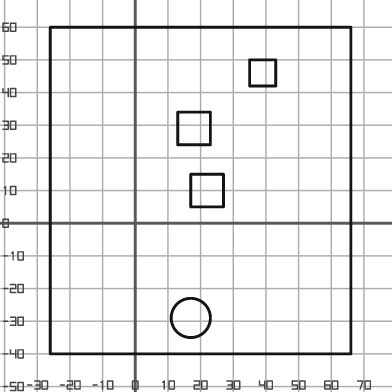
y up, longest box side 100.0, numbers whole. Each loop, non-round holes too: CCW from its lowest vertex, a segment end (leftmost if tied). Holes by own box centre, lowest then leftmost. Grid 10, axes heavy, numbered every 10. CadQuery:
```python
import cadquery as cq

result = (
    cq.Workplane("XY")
    .moveTo(-26.0, -40.0)
    .lineTo(66.0, -40.0)
    .lineTo(66.0, 60.0)
    .lineTo(-26.0, 60.0)
    .close()
    .moveTo(17.0, -29.0)
    .circle(6.0)
    .moveTo(17.0, 5.0)
    .lineTo(27.0, 5.0)
    .lineTo(27.0, 15.0)
    .lineTo(17.0, 15.0)
    .close()
    .moveTo(13.0, 24.0)
    .lineTo(23.0, 24.0)
    .lineTo(23.0, 34.0)
    .lineTo(13.0, 34.0)
    .close()
    .moveTo(35.0, 42.0)
    .lineTo(43.0, 42.0)
    .lineTo(43.0, 50.0)
    .lineTo(35.0, 50.0)
    .close()
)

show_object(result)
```